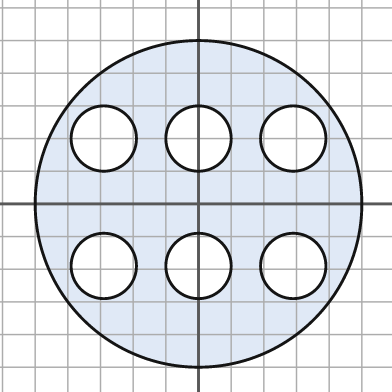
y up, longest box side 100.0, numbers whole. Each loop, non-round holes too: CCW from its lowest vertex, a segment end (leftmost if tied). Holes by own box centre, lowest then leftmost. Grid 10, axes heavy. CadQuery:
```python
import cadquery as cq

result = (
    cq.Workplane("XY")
    .moveTo(0.0, 0.0)
    .circle(50.0)
    .moveTo(-29.0, -19.0)
    .circle(10.0)
    .moveTo(0.0, -19.0)
    .circle(10.0)
    .moveTo(29.0, -19.0)
    .circle(10.0)
    .moveTo(-29.0, 20.0)
    .circle(10.0)
    .moveTo(0.0, 20.0)
    .circle(10.0)
    .moveTo(29.0, 20.0)
    .circle(10.0)
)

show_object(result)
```